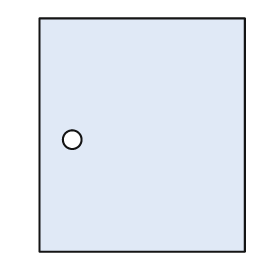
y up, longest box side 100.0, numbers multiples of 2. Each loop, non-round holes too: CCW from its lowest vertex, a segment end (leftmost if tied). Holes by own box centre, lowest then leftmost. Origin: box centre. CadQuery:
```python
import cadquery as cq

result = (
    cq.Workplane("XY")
    .moveTo(-44.0, -50.0)
    .lineTo(44.0, -50.0)
    .lineTo(44.0, 50.0)
    .lineTo(-44.0, 50.0)
    .close()
    .moveTo(-30.0, -2.0)
    .circle(4.0)
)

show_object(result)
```